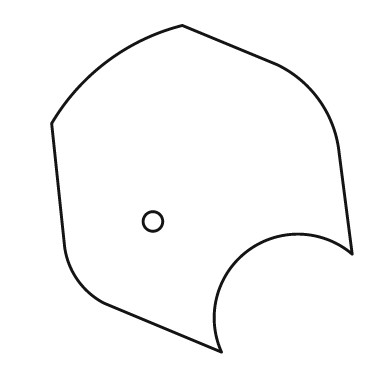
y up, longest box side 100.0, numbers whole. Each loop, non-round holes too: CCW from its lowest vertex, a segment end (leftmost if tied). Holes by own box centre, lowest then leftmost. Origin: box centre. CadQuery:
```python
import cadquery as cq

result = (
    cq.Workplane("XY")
    .moveTo(6.0, -50.0)
    .threePointArc((14.0, -19.0), (46.0, -20.0))
    .lineTo(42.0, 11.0)
    .threePointArc((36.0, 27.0), (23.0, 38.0))
    .lineTo(-6.0, 50.0)
    .threePointArc((-29.0, 39.0), (-46.0, 20.0))
    .lineTo(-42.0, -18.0)
    .threePointArc((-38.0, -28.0), (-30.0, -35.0))
    .close()
    .moveTo(-15.0, -10.0)
    .circle(3.0)
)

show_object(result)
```